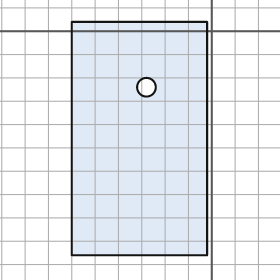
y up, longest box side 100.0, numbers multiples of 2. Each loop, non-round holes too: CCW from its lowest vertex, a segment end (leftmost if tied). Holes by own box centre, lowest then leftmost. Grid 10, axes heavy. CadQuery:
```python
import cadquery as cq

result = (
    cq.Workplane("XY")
    .moveTo(-60.0, -96.0)
    .lineTo(-2.0, -96.0)
    .lineTo(-2.0, 4.0)
    .lineTo(-60.0, 4.0)
    .close()
    .moveTo(-28.0, -24.0)
    .circle(4.0)
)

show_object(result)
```